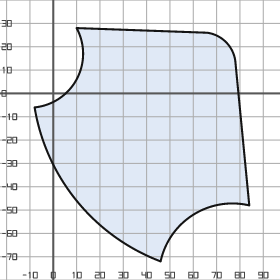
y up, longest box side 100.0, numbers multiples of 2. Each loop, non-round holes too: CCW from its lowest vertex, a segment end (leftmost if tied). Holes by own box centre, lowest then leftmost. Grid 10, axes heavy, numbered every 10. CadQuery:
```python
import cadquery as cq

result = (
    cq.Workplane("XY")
    .moveTo(46.0, -72.0)
    .threePointArc((60.0, -52.0), (84.0, -48.0))
    .lineTo(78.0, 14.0)
    .threePointArc((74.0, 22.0), (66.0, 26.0))
    .lineTo(10.0, 28.0)
    .threePointArc((10.0, 6.0), (-8.0, -6.0))
    .threePointArc((10.0, -46.0), (46.0, -72.0))
    .close()
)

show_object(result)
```